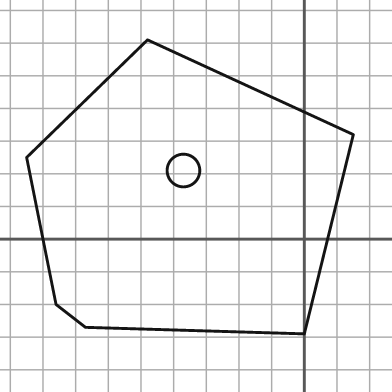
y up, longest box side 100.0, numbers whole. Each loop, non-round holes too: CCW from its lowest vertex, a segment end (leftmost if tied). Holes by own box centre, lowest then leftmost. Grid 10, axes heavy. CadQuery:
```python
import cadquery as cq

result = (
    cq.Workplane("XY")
    .moveTo(0.0, -29.0)
    .lineTo(15.0, 32.0)
    .lineTo(-48.0, 61.0)
    .lineTo(-85.0, 25.0)
    .lineTo(-76.0, -20.0)
    .lineTo(-67.0, -27.0)
    .close()
    .moveTo(-37.0, 21.0)
    .circle(5.0)
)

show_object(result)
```